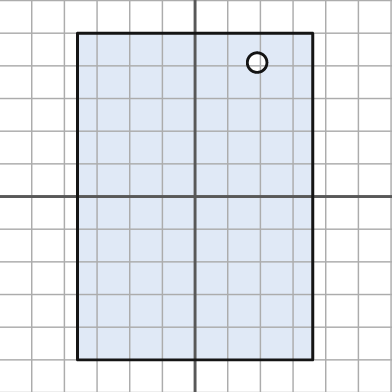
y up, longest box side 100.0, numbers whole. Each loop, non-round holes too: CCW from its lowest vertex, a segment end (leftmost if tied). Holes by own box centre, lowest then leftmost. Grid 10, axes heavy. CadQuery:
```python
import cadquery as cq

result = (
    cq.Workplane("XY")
    .moveTo(-36.0, -50.0)
    .lineTo(36.0, -50.0)
    .lineTo(36.0, 50.0)
    .lineTo(-36.0, 50.0)
    .close()
    .moveTo(19.0, 41.0)
    .circle(3.0)
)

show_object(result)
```